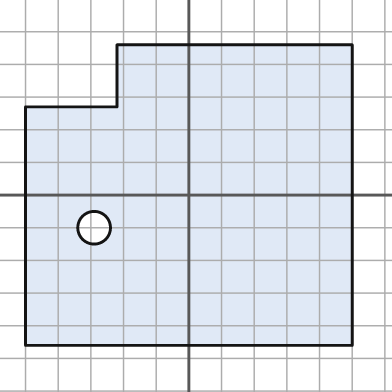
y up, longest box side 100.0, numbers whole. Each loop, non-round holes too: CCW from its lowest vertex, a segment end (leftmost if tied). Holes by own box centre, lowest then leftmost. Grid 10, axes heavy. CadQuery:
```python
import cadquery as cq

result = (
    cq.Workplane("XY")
    .moveTo(-50.0, -46.0)
    .lineTo(50.0, -46.0)
    .lineTo(50.0, 46.0)
    .lineTo(-22.0, 46.0)
    .lineTo(-22.0, 27.0)
    .lineTo(-50.0, 27.0)
    .close()
    .moveTo(-29.0, -10.0)
    .circle(5.0)
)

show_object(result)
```